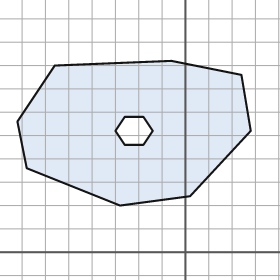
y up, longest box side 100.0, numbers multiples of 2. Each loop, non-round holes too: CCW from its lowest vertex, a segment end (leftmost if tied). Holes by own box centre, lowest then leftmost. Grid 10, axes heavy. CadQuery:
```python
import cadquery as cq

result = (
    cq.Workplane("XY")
    .moveTo(-28.0, 20.0)
    .lineTo(2.0, 24.0)
    .lineTo(28.0, 52.0)
    .lineTo(24.0, 76.0)
    .lineTo(-6.0, 82.0)
    .lineTo(-56.0, 80.0)
    .lineTo(-72.0, 56.0)
    .lineTo(-68.0, 36.0)
    .close()
    .moveTo(-26.0, 46.0)
    .lineTo(-18.0, 46.0)
    .lineTo(-14.0, 52.0)
    .lineTo(-18.0, 58.0)
    .lineTo(-26.0, 58.0)
    .lineTo(-30.0, 52.0)
    .close()
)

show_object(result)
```